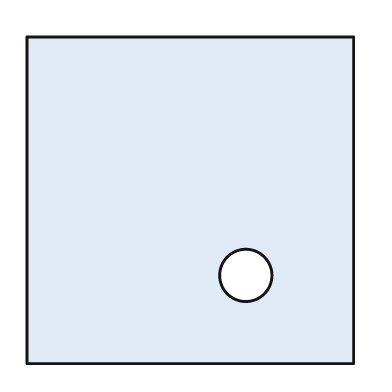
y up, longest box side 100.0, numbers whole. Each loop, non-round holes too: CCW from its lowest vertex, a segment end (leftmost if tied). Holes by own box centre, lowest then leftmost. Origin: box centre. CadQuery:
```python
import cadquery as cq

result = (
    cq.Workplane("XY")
    .moveTo(-50.0, -50.0)
    .lineTo(50.0, -50.0)
    .lineTo(50.0, 50.0)
    .lineTo(-50.0, 50.0)
    .close()
    .moveTo(17.0, -23.0)
    .circle(8.0)
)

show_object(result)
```